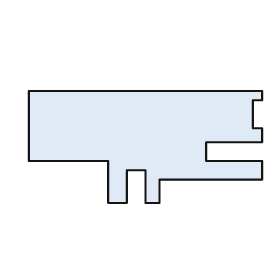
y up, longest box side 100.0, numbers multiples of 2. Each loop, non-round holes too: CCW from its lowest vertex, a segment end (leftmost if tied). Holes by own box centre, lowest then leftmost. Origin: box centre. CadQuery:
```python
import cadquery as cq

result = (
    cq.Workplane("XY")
    .moveTo(-16.0, -24.0)
    .lineTo(-8.0, -24.0)
    .lineTo(-8.0, -10.0)
    .lineTo(0.0, -10.0)
    .lineTo(0.0, -24.0)
    .lineTo(6.0, -24.0)
    .lineTo(6.0, -14.0)
    .lineTo(50.0, -14.0)
    .lineTo(50.0, -6.0)
    .lineTo(26.0, -6.0)
    .lineTo(26.0, 2.0)
    .lineTo(50.0, 2.0)
    .lineTo(50.0, 8.0)
    .lineTo(46.0, 8.0)
    .lineTo(46.0, 20.0)
    .lineTo(50.0, 20.0)
    .lineTo(50.0, 24.0)
    .lineTo(-50.0, 24.0)
    .lineTo(-50.0, -6.0)
    .lineTo(-16.0, -6.0)
    .close()
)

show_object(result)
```